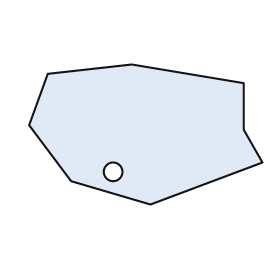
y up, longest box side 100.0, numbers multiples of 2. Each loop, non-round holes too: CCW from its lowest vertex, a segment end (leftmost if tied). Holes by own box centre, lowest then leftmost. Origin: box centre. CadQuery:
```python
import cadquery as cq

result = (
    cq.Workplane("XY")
    .moveTo(2.0, -30.0)
    .lineTo(50.0, -12.0)
    .lineTo(42.0, 2.0)
    .lineTo(42.0, 22.0)
    .lineTo(-6.0, 30.0)
    .lineTo(-42.0, 26.0)
    .lineTo(-50.0, 4.0)
    .lineTo(-32.0, -20.0)
    .close()
    .moveTo(-14.0, -16.0)
    .circle(4.0)
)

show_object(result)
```